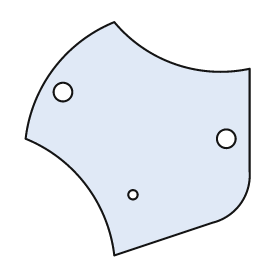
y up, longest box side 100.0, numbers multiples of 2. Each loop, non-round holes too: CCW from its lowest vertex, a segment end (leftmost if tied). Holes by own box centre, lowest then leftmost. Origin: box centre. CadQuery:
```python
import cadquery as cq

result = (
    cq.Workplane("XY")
    .moveTo(-10.0, -50.0)
    .lineTo(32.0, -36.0)
    .threePointArc((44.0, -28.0), (48.0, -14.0))
    .lineTo(48.0, 30.0)
    .threePointArc((16.0, 32.0), (-10.0, 50.0))
    .threePointArc((-36.0, 30.0), (-48.0, 0.0))
    .threePointArc((-22.0, -20.0), (-10.0, -50.0))
    .close()
    .moveTo(-2.0, -24.0)
    .circle(2.0)
    .moveTo(38.0, 0.0)
    .circle(4.0)
    .moveTo(-32.0, 20.0)
    .circle(4.0)
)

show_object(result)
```